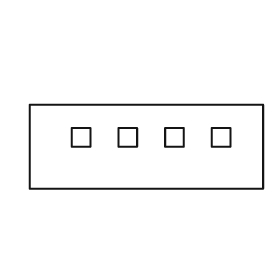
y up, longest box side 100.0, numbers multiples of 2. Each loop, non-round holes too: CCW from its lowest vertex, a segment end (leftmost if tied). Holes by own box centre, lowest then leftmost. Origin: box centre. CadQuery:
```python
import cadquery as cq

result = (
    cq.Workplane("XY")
    .moveTo(-50.0, -18.0)
    .lineTo(50.0, -18.0)
    .lineTo(50.0, 18.0)
    .lineTo(-50.0, 18.0)
    .close()
    .moveTo(-32.0, 0.0)
    .lineTo(-24.0, 0.0)
    .lineTo(-24.0, 8.0)
    .lineTo(-32.0, 8.0)
    .close()
    .moveTo(-12.0, 0.0)
    .lineTo(-4.0, 0.0)
    .lineTo(-4.0, 8.0)
    .lineTo(-12.0, 8.0)
    .close()
    .moveTo(8.0, 0.0)
    .lineTo(16.0, 0.0)
    .lineTo(16.0, 8.0)
    .lineTo(8.0, 8.0)
    .close()
    .moveTo(28.0, 0.0)
    .lineTo(36.0, 0.0)
    .lineTo(36.0, 8.0)
    .lineTo(28.0, 8.0)
    .close()
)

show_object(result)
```